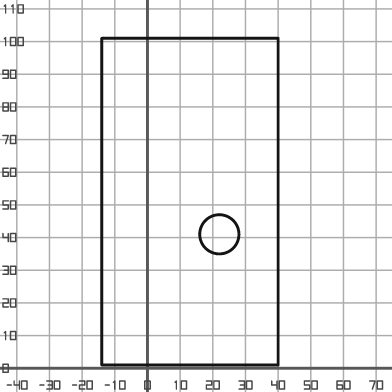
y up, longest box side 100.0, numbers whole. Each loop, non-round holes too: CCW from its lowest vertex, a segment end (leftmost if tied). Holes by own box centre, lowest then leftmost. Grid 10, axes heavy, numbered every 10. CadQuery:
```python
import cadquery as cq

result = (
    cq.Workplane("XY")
    .moveTo(-14.0, 1.0)
    .lineTo(40.0, 1.0)
    .lineTo(40.0, 101.0)
    .lineTo(-14.0, 101.0)
    .close()
    .moveTo(22.0, 41.0)
    .circle(6.0)
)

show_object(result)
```